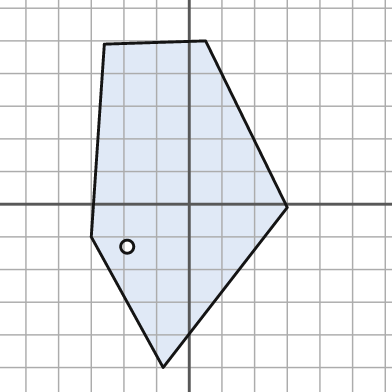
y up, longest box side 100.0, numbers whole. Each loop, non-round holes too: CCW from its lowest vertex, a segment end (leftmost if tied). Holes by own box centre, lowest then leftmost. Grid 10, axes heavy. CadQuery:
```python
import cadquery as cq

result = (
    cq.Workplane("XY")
    .moveTo(-8.0, -50.0)
    .lineTo(30.0, -1.0)
    .lineTo(5.0, 50.0)
    .lineTo(-26.0, 49.0)
    .lineTo(-30.0, -10.0)
    .close()
    .moveTo(-19.0, -13.0)
    .circle(2.0)
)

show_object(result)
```